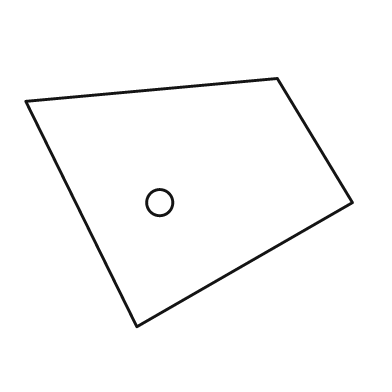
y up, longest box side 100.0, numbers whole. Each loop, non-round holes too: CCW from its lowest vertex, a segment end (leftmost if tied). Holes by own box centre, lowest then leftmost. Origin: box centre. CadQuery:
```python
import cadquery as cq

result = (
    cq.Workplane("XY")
    .moveTo(-16.0, -38.0)
    .lineTo(50.0, 0.0)
    .lineTo(27.0, 38.0)
    .lineTo(-50.0, 31.0)
    .close()
    .moveTo(-9.0, 0.0)
    .circle(4.0)
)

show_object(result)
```